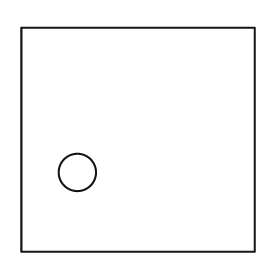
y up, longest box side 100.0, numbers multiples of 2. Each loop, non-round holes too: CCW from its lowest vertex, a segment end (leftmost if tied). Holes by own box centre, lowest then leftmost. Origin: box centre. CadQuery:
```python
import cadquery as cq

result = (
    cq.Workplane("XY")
    .moveTo(-50.0, -48.0)
    .lineTo(50.0, -48.0)
    .lineTo(50.0, 48.0)
    .lineTo(-50.0, 48.0)
    .close()
    .moveTo(-26.0, -14.0)
    .circle(8.0)
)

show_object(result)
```